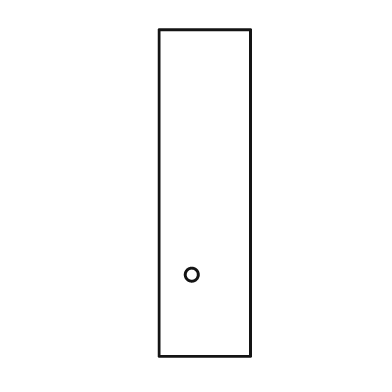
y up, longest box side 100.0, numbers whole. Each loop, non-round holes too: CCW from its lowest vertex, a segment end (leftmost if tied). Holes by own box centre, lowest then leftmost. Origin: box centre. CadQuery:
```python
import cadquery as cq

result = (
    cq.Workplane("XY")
    .moveTo(-14.0, -50.0)
    .lineTo(14.0, -50.0)
    .lineTo(14.0, 50.0)
    .lineTo(-14.0, 50.0)
    .close()
    .moveTo(-4.0, -25.0)
    .circle(2.0)
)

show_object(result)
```